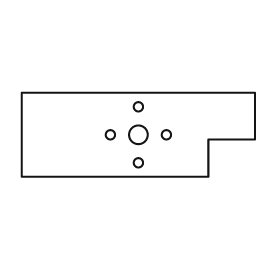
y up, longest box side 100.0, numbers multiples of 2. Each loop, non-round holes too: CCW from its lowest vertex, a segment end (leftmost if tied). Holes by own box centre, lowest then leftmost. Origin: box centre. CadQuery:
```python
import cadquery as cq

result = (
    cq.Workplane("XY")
    .moveTo(-50.0, -18.0)
    .lineTo(30.0, -18.0)
    .lineTo(30.0, -2.0)
    .lineTo(50.0, -2.0)
    .lineTo(50.0, 18.0)
    .lineTo(-50.0, 18.0)
    .close()
    .moveTo(0.0, -12.0)
    .circle(2.0)
    .moveTo(-12.0, 0.0)
    .circle(2.0)
    .moveTo(0.0, 0.0)
    .circle(4.0)
    .moveTo(12.0, 0.0)
    .circle(2.0)
    .moveTo(0.0, 12.0)
    .circle(2.0)
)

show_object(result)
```